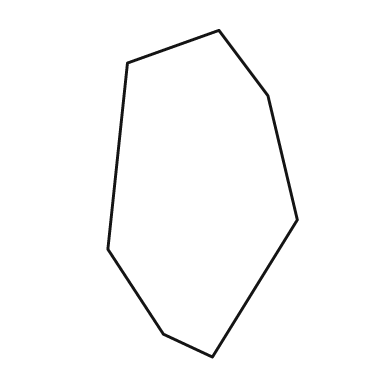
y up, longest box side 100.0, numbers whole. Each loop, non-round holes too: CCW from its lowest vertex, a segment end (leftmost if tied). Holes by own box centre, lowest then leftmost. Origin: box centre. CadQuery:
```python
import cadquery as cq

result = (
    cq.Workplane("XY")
    .moveTo(3.0, -50.0)
    .lineTo(29.0, -8.0)
    .lineTo(20.0, 30.0)
    .lineTo(5.0, 50.0)
    .lineTo(-23.0, 40.0)
    .lineTo(-29.0, -17.0)
    .lineTo(-12.0, -43.0)
    .close()
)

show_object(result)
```